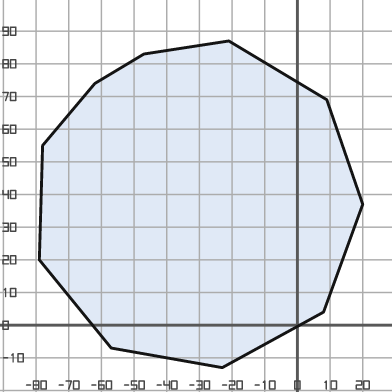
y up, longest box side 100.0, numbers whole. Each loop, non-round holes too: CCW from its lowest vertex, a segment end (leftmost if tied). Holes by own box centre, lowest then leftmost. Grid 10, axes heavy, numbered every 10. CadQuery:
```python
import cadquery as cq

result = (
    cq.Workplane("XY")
    .moveTo(-23.0, -13.0)
    .lineTo(8.0, 4.0)
    .lineTo(20.0, 37.0)
    .lineTo(9.0, 69.0)
    .lineTo(-21.0, 87.0)
    .lineTo(-47.0, 83.0)
    .lineTo(-62.0, 74.0)
    .lineTo(-78.0, 55.0)
    .lineTo(-79.0, 20.0)
    .lineTo(-57.0, -7.0)
    .close()
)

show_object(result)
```